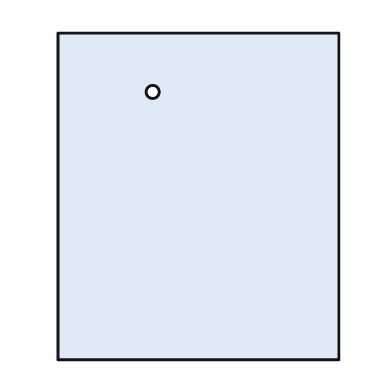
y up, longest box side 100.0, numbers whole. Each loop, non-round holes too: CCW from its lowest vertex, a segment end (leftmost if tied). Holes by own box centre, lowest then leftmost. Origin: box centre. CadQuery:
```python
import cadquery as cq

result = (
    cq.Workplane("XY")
    .moveTo(-43.0, -50.0)
    .lineTo(43.0, -50.0)
    .lineTo(43.0, 50.0)
    .lineTo(-43.0, 50.0)
    .close()
    .moveTo(-14.0, 32.0)
    .circle(2.0)
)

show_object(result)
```